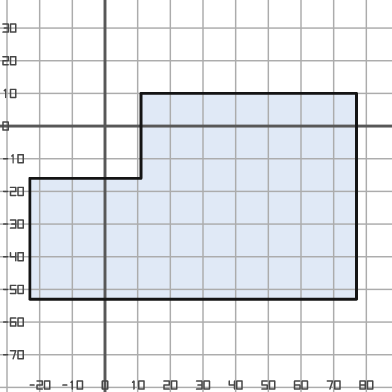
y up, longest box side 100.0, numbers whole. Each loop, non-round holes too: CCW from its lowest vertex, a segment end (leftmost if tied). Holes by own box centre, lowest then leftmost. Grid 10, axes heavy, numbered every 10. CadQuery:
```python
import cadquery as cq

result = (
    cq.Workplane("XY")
    .moveTo(-23.0, -53.0)
    .lineTo(77.0, -53.0)
    .lineTo(77.0, 10.0)
    .lineTo(11.0, 10.0)
    .lineTo(11.0, -16.0)
    .lineTo(-23.0, -16.0)
    .close()
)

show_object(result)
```